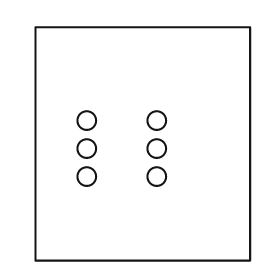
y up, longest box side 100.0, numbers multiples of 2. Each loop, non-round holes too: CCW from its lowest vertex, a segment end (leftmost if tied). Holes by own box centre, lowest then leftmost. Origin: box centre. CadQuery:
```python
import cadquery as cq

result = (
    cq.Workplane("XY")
    .moveTo(-46.0, -50.0)
    .lineTo(46.0, -50.0)
    .lineTo(46.0, 50.0)
    .lineTo(-46.0, 50.0)
    .close()
    .moveTo(-24.0, -14.0)
    .circle(4.0)
    .moveTo(6.0, -14.0)
    .circle(4.0)
    .moveTo(-24.0, -2.0)
    .circle(4.0)
    .moveTo(6.0, -2.0)
    .circle(4.0)
    .moveTo(-24.0, 10.0)
    .circle(4.0)
    .moveTo(6.0, 10.0)
    .circle(4.0)
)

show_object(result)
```